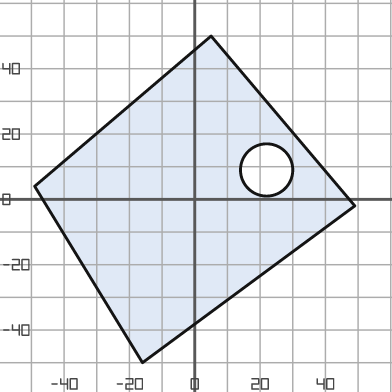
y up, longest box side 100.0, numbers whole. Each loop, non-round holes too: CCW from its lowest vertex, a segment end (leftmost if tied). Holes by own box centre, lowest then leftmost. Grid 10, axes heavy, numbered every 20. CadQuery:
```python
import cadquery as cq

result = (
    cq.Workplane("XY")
    .moveTo(-16.0, -50.0)
    .lineTo(49.0, -2.0)
    .lineTo(5.0, 50.0)
    .lineTo(-49.0, 4.0)
    .close()
    .moveTo(22.0, 9.0)
    .circle(8.0)
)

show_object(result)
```